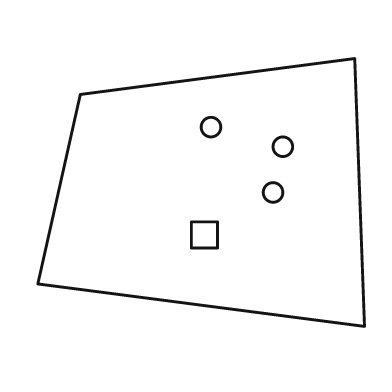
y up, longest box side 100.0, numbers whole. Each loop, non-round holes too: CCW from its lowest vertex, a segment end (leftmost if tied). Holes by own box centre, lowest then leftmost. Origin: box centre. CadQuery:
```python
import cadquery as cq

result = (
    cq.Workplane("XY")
    .moveTo(50.0, -41.0)
    .lineTo(47.0, 41.0)
    .lineTo(-37.0, 30.0)
    .lineTo(-50.0, -28.0)
    .close()
    .moveTo(-3.0, -17.0)
    .lineTo(5.0, -17.0)
    .lineTo(5.0, -9.0)
    .lineTo(-3.0, -9.0)
    .close()
    .moveTo(22.0, 0.0)
    .circle(3.0)
    .moveTo(25.0, 14.0)
    .circle(3.0)
    .moveTo(3.0, 20.0)
    .circle(3.0)
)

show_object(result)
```